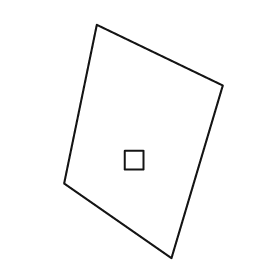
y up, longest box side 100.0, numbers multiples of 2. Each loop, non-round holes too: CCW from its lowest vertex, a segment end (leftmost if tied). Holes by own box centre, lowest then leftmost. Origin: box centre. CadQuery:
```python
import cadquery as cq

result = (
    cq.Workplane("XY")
    .moveTo(12.0, -50.0)
    .lineTo(34.0, 24.0)
    .lineTo(-20.0, 50.0)
    .lineTo(-34.0, -18.0)
    .close()
    .moveTo(-8.0, -12.0)
    .lineTo(0.0, -12.0)
    .lineTo(0.0, -4.0)
    .lineTo(-8.0, -4.0)
    .close()
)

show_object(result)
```